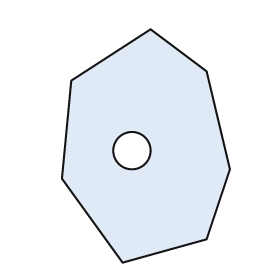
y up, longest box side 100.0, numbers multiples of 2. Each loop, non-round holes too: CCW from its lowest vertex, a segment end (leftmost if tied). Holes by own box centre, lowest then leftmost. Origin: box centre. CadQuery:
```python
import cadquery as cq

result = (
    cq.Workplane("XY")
    .moveTo(-10.0, -50.0)
    .lineTo(26.0, -40.0)
    .lineTo(36.0, -10.0)
    .lineTo(26.0, 32.0)
    .lineTo(2.0, 50.0)
    .lineTo(-32.0, 28.0)
    .lineTo(-36.0, -14.0)
    .close()
    .moveTo(-6.0, -2.0)
    .circle(8.0)
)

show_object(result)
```